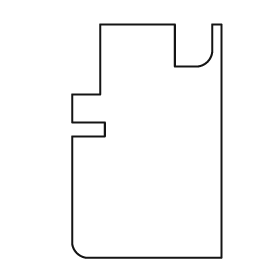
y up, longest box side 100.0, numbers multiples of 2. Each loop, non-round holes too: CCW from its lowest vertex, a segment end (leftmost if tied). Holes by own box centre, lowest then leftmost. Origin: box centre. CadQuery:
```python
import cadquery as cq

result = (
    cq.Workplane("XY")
    .moveTo(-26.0, -50.0)
    .lineTo(32.0, -50.0)
    .lineTo(32.0, 50.0)
    .lineTo(28.0, 50.0)
    .lineTo(28.0, 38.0)
    .threePointArc((26.0, 34.0), (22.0, 32.0))
    .lineTo(12.0, 32.0)
    .lineTo(12.0, 50.0)
    .lineTo(-20.0, 50.0)
    .lineTo(-20.0, 20.0)
    .lineTo(-32.0, 20.0)
    .lineTo(-32.0, 8.0)
    .lineTo(-18.0, 8.0)
    .lineTo(-18.0, 2.0)
    .lineTo(-32.0, 2.0)
    .lineTo(-32.0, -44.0)
    .threePointArc((-30.0, -48.0), (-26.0, -50.0))
    .close()
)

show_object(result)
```